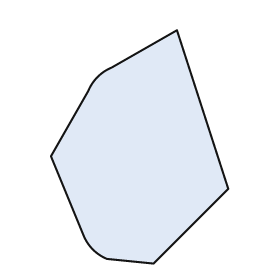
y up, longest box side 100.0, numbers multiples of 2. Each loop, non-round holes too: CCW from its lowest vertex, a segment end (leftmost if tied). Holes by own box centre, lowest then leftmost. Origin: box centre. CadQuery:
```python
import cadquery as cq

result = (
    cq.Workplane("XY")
    .moveTo(6.0, -50.0)
    .lineTo(38.0, -18.0)
    .lineTo(16.0, 50.0)
    .lineTo(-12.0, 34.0)
    .threePointArc((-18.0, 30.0), (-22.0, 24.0))
    .lineTo(-38.0, -4.0)
    .lineTo(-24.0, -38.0)
    .threePointArc((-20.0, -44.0), (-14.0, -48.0))
    .close()
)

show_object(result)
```